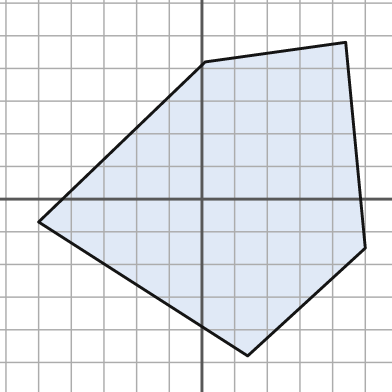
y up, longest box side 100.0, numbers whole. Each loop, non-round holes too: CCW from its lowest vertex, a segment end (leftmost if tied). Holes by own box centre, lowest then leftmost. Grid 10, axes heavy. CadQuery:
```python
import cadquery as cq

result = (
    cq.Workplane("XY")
    .moveTo(14.0, -48.0)
    .lineTo(50.0, -15.0)
    .lineTo(44.0, 48.0)
    .lineTo(1.0, 42.0)
    .lineTo(-50.0, -7.0)
    .close()
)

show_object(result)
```